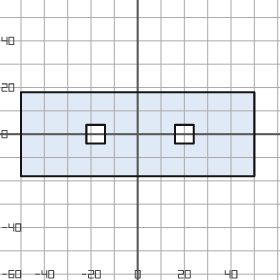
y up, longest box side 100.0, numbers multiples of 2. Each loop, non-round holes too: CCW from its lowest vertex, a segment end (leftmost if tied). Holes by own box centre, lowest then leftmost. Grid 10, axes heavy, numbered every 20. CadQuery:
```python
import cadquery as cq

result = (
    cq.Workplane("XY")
    .moveTo(-50.0, -18.0)
    .lineTo(50.0, -18.0)
    .lineTo(50.0, 18.0)
    .lineTo(-50.0, 18.0)
    .close()
    .moveTo(-22.0, -4.0)
    .lineTo(-14.0, -4.0)
    .lineTo(-14.0, 4.0)
    .lineTo(-22.0, 4.0)
    .close()
    .moveTo(16.0, -4.0)
    .lineTo(24.0, -4.0)
    .lineTo(24.0, 4.0)
    .lineTo(16.0, 4.0)
    .close()
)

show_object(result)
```